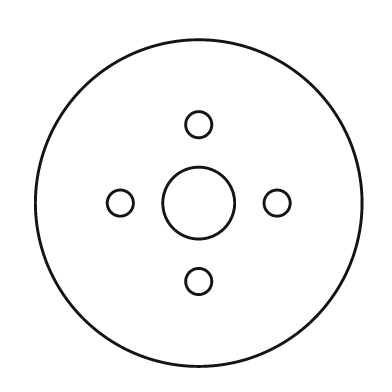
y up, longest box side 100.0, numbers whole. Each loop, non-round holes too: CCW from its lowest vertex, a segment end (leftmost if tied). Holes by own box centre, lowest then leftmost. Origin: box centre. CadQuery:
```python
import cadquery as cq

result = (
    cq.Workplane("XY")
    .moveTo(0.0, 0.0)
    .circle(50.0)
    .moveTo(0.0, -24.0)
    .circle(4.0)
    .moveTo(-24.0, 0.0)
    .circle(4.0)
    .moveTo(0.0, 0.0)
    .circle(11.0)
    .moveTo(24.0, 0.0)
    .circle(4.0)
    .moveTo(0.0, 24.0)
    .circle(4.0)
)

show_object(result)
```